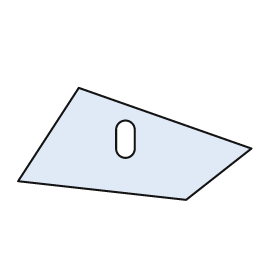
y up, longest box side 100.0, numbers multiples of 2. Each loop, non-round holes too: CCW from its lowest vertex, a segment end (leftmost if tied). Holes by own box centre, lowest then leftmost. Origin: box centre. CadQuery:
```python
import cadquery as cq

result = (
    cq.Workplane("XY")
    .moveTo(22.0, -24.0)
    .lineTo(50.0, -2.0)
    .lineTo(-24.0, 24.0)
    .lineTo(-50.0, -16.0)
    .close()
    .moveTo(-8.0, -2.0)
    .threePointArc((-4.0, -6.0), (0.0, -2.0))
    .lineTo(0.0, 6.0)
    .threePointArc((-4.0, 10.0), (-8.0, 6.0))
    .close()
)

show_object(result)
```